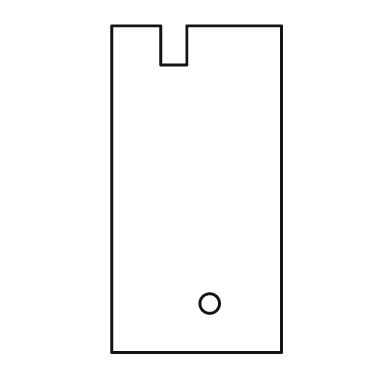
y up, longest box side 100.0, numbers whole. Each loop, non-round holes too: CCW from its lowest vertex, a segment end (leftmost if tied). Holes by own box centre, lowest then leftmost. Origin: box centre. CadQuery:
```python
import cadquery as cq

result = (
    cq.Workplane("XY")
    .moveTo(-26.0, -50.0)
    .lineTo(26.0, -50.0)
    .lineTo(26.0, 50.0)
    .lineTo(-3.0, 50.0)
    .lineTo(-3.0, 38.0)
    .lineTo(-11.0, 38.0)
    .lineTo(-11.0, 50.0)
    .lineTo(-26.0, 50.0)
    .close()
    .moveTo(4.0, -35.0)
    .circle(3.0)
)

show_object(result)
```